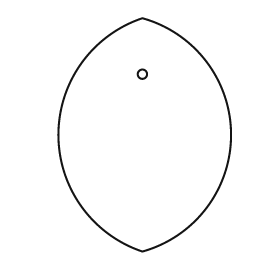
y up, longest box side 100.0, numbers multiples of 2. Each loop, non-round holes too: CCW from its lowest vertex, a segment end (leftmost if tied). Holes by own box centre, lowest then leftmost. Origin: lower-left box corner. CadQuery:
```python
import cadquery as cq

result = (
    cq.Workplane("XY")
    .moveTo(36.0, 0.0)
    .threePointArc((74.0, 50.0), (36.0, 100.0))
    .threePointArc((0.0, 50.0), (36.0, 0.0))
    .close()
    .moveTo(36.0, 76.0)
    .circle(2.0)
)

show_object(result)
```